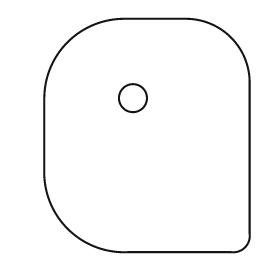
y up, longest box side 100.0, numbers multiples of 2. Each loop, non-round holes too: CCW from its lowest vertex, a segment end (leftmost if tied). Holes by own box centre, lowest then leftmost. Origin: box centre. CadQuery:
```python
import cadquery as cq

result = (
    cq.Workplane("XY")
    .moveTo(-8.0, -50.0)
    .lineTo(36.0, -50.0)
    .threePointArc((42.0, -48.0), (44.0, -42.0))
    .lineTo(44.0, 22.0)
    .threePointArc((36.0, 42.0), (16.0, 50.0))
    .lineTo(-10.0, 50.0)
    .threePointArc((-34.0, 40.0), (-44.0, 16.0))
    .lineTo(-44.0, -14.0)
    .threePointArc((-34.0, -40.0), (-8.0, -50.0))
    .close()
    .moveTo(-6.0, 16.0)
    .circle(6.0)
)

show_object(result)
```